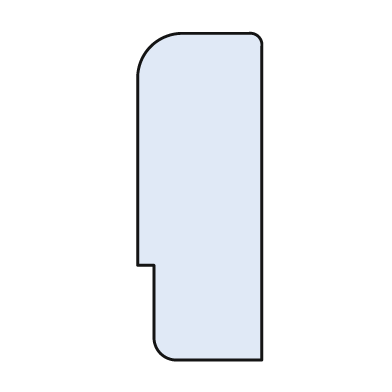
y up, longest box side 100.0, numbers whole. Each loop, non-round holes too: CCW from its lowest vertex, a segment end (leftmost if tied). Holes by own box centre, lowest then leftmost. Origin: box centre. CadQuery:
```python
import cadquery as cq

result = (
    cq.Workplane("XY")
    .moveTo(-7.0, -50.0)
    .lineTo(19.0, -50.0)
    .lineTo(19.0, 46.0)
    .threePointArc((18.0, 49.0), (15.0, 50.0))
    .lineTo(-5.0, 50.0)
    .threePointArc((-15.0, 46.0), (-19.0, 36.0))
    .lineTo(-19.0, -21.0)
    .lineTo(-14.0, -21.0)
    .lineTo(-14.0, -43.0)
    .threePointArc((-12.0, -48.0), (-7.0, -50.0))
    .close()
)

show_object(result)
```